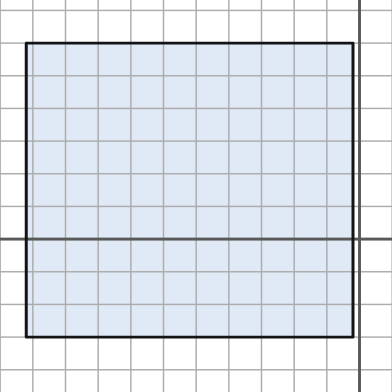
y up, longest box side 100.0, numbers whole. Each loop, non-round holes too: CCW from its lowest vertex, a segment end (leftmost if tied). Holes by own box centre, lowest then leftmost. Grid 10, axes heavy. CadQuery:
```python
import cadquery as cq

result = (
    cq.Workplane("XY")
    .moveTo(-102.0, -30.0)
    .lineTo(-2.0, -30.0)
    .lineTo(-2.0, 60.0)
    .lineTo(-102.0, 60.0)
    .close()
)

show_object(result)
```